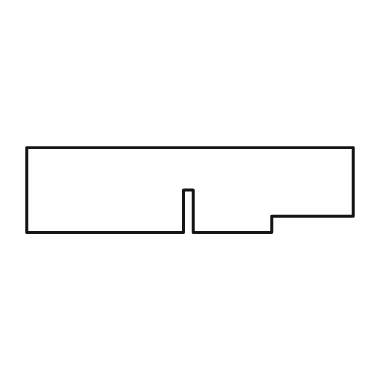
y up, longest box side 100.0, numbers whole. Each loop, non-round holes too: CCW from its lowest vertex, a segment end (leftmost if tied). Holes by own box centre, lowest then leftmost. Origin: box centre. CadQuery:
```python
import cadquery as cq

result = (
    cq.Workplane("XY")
    .moveTo(-50.0, -13.0)
    .lineTo(-2.0, -13.0)
    .lineTo(-2.0, 0.0)
    .lineTo(1.0, 0.0)
    .lineTo(1.0, -13.0)
    .lineTo(25.0, -13.0)
    .lineTo(25.0, -8.0)
    .lineTo(50.0, -8.0)
    .lineTo(50.0, 13.0)
    .lineTo(-50.0, 13.0)
    .close()
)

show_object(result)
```